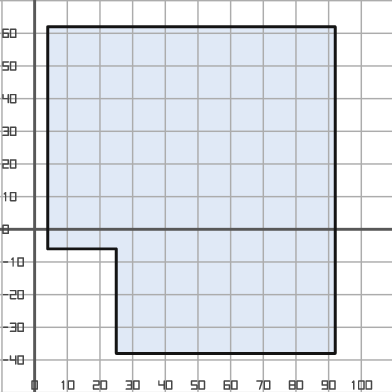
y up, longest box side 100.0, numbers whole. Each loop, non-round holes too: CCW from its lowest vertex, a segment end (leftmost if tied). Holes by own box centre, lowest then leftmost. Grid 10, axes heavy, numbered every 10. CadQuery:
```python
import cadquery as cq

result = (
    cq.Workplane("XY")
    .moveTo(25.0, -38.0)
    .lineTo(92.0, -38.0)
    .lineTo(92.0, 62.0)
    .lineTo(4.0, 62.0)
    .lineTo(4.0, -6.0)
    .lineTo(25.0, -6.0)
    .close()
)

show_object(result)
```